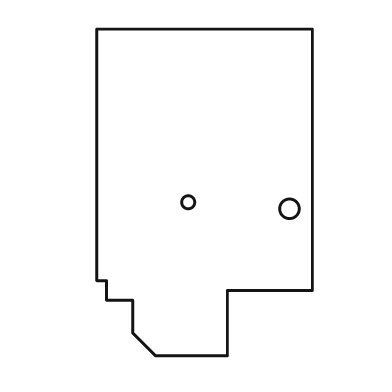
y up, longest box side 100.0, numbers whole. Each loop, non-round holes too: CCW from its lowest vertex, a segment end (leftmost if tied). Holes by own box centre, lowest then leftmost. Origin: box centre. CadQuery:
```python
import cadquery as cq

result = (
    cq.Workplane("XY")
    .moveTo(-15.0, -50.0)
    .lineTo(7.0, -50.0)
    .lineTo(7.0, -30.0)
    .lineTo(33.0, -30.0)
    .lineTo(33.0, 50.0)
    .lineTo(-33.0, 50.0)
    .lineTo(-33.0, -27.0)
    .lineTo(-30.0, -27.0)
    .lineTo(-30.0, -33.0)
    .lineTo(-22.0, -33.0)
    .lineTo(-22.0, -43.0)
    .close()
    .moveTo(26.0, -5.0)
    .circle(3.0)
    .moveTo(-5.0, -3.0)
    .circle(2.0)
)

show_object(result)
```